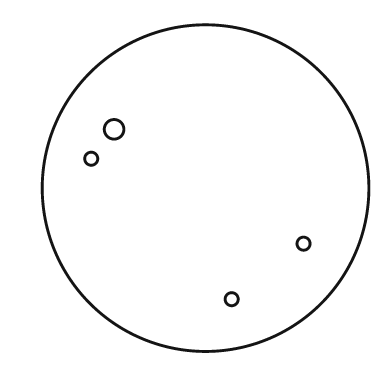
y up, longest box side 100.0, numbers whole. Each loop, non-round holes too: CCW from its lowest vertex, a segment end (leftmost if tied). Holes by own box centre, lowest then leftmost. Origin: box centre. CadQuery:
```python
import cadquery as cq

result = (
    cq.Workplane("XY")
    .moveTo(0.0, 0.0)
    .circle(50.0)
    .moveTo(8.0, -34.0)
    .circle(2.0)
    .moveTo(30.0, -17.0)
    .circle(2.0)
    .moveTo(-35.0, 9.0)
    .circle(2.0)
    .moveTo(-28.0, 18.0)
    .circle(3.0)
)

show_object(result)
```